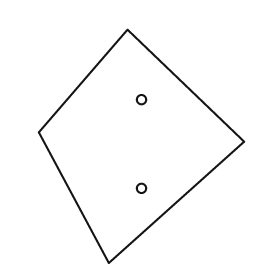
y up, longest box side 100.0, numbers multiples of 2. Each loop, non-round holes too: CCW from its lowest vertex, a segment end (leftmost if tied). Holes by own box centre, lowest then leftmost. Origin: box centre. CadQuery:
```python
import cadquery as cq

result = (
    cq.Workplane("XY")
    .moveTo(-14.0, -50.0)
    .lineTo(44.0, 2.0)
    .lineTo(-6.0, 50.0)
    .lineTo(-44.0, 6.0)
    .close()
    .moveTo(0.0, -18.0)
    .circle(2.0)
    .moveTo(0.0, 20.0)
    .circle(2.0)
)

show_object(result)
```